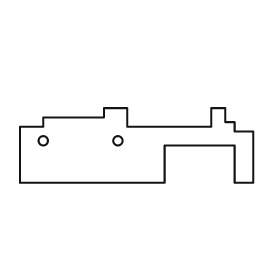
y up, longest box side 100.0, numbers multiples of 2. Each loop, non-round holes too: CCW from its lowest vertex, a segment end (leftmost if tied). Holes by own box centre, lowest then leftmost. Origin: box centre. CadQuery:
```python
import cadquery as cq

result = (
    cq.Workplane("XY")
    .moveTo(-50.0, -16.0)
    .lineTo(12.0, -16.0)
    .lineTo(12.0, 0.0)
    .lineTo(42.0, 0.0)
    .lineTo(42.0, -16.0)
    .lineTo(50.0, -16.0)
    .lineTo(50.0, 6.0)
    .lineTo(42.0, 6.0)
    .lineTo(42.0, 10.0)
    .lineTo(38.0, 10.0)
    .lineTo(38.0, 16.0)
    .lineTo(32.0, 16.0)
    .lineTo(32.0, 8.0)
    .lineTo(-4.0, 8.0)
    .lineTo(-4.0, 16.0)
    .lineTo(-14.0, 16.0)
    .lineTo(-14.0, 12.0)
    .lineTo(-40.0, 12.0)
    .lineTo(-40.0, 8.0)
    .lineTo(-50.0, 8.0)
    .close()
    .moveTo(-40.0, 2.0)
    .circle(2.0)
    .moveTo(-8.0, 2.0)
    .circle(2.0)
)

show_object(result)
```